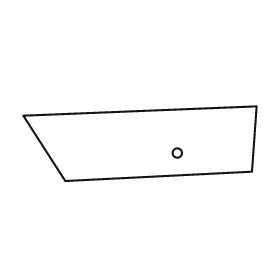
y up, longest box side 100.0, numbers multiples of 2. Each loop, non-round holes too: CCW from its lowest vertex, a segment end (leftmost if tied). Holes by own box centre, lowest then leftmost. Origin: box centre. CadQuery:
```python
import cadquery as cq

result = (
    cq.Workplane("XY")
    .moveTo(-32.0, -16.0)
    .lineTo(48.0, -12.0)
    .lineTo(50.0, 16.0)
    .lineTo(-50.0, 12.0)
    .close()
    .moveTo(16.0, -4.0)
    .circle(2.0)
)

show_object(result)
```